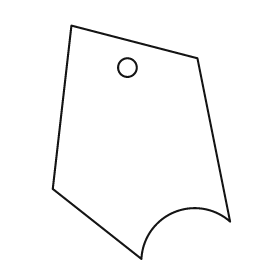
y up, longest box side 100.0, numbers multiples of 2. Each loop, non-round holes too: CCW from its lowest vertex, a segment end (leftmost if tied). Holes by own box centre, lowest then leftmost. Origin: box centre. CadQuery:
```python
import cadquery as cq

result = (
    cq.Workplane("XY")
    .moveTo(0.0, -50.0)
    .threePointArc((14.0, -30.0), (38.0, -34.0))
    .lineTo(24.0, 36.0)
    .lineTo(-30.0, 50.0)
    .lineTo(-38.0, -20.0)
    .close()
    .moveTo(-6.0, 32.0)
    .circle(4.0)
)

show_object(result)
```